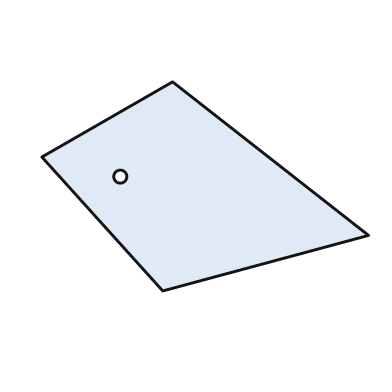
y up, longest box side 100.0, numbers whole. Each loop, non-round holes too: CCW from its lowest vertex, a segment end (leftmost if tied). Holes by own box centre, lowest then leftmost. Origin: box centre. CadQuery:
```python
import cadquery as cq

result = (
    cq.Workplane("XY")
    .moveTo(-13.0, -32.0)
    .lineTo(50.0, -15.0)
    .lineTo(-10.0, 32.0)
    .lineTo(-50.0, 9.0)
    .close()
    .moveTo(-26.0, 3.0)
    .circle(2.0)
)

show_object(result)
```